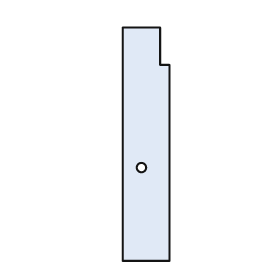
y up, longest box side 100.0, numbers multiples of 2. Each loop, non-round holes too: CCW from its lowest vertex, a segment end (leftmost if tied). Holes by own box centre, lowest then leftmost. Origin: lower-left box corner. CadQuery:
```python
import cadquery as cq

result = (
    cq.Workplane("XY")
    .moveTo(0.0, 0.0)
    .lineTo(20.0, 0.0)
    .lineTo(20.0, 84.0)
    .lineTo(16.0, 84.0)
    .lineTo(16.0, 100.0)
    .lineTo(0.0, 100.0)
    .close()
    .moveTo(8.0, 40.0)
    .circle(2.0)
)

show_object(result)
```